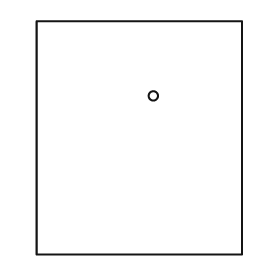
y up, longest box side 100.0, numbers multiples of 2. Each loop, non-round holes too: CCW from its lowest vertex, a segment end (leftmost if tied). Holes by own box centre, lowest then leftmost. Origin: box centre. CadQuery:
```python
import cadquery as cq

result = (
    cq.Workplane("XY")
    .moveTo(-44.0, -50.0)
    .lineTo(44.0, -50.0)
    .lineTo(44.0, 50.0)
    .lineTo(-44.0, 50.0)
    .close()
    .moveTo(6.0, 18.0)
    .circle(2.0)
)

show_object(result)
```